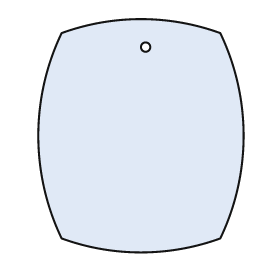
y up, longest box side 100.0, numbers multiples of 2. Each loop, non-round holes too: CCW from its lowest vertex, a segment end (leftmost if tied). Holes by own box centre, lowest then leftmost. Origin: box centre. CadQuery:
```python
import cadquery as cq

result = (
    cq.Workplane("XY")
    .moveTo(-34.0, -44.0)
    .threePointArc((0.0, -50.0), (34.0, -44.0))
    .threePointArc((44.0, 0.0), (34.0, 44.0))
    .threePointArc((0.0, 50.0), (-34.0, 44.0))
    .threePointArc((-44.0, 0.0), (-34.0, -44.0))
    .close()
    .moveTo(2.0, 38.0)
    .circle(2.0)
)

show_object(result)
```